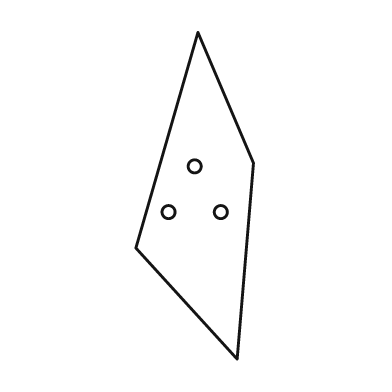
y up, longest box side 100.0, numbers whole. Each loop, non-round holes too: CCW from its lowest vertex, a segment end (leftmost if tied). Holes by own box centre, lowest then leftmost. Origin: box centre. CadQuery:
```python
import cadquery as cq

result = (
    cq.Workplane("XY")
    .moveTo(13.0, -50.0)
    .lineTo(18.0, 10.0)
    .lineTo(1.0, 50.0)
    .lineTo(-18.0, -16.0)
    .close()
    .moveTo(-8.0, -5.0)
    .circle(2.0)
    .moveTo(8.0, -5.0)
    .circle(2.0)
    .moveTo(0.0, 9.0)
    .circle(2.0)
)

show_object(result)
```